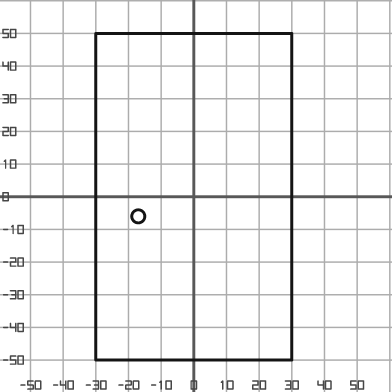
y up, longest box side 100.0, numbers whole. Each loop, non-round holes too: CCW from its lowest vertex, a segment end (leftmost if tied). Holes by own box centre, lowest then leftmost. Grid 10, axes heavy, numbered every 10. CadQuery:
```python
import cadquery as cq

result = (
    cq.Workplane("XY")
    .moveTo(-30.0, -50.0)
    .lineTo(30.0, -50.0)
    .lineTo(30.0, 50.0)
    .lineTo(-30.0, 50.0)
    .close()
    .moveTo(-17.0, -6.0)
    .circle(2.0)
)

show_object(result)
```